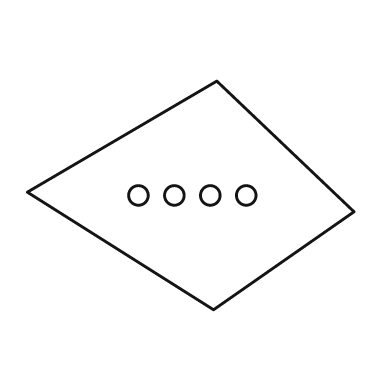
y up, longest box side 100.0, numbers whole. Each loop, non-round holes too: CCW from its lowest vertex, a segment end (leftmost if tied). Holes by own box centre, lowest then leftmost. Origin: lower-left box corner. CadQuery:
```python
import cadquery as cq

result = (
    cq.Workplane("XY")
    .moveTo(57.0, 0.0)
    .lineTo(100.0, 30.0)
    .lineTo(58.0, 70.0)
    .lineTo(0.0, 36.0)
    .close()
    .moveTo(34.0, 35.0)
    .circle(3.0)
    .moveTo(45.0, 35.0)
    .circle(3.0)
    .moveTo(56.0, 35.0)
    .circle(3.0)
    .moveTo(67.0, 35.0)
    .circle(3.0)
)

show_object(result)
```